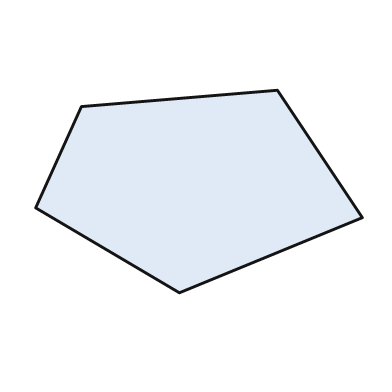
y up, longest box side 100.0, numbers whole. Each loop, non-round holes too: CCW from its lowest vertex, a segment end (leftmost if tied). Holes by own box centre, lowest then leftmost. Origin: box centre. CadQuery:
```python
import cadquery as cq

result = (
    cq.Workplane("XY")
    .moveTo(-6.0, -31.0)
    .lineTo(50.0, -8.0)
    .lineTo(24.0, 31.0)
    .lineTo(-36.0, 26.0)
    .lineTo(-50.0, -5.0)
    .close()
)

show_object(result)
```